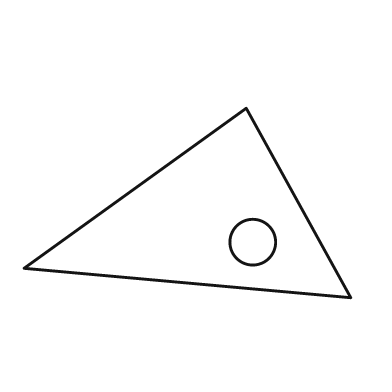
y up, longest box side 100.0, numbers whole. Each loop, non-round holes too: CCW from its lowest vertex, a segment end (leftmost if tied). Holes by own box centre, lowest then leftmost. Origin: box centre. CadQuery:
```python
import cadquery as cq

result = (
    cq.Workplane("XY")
    .moveTo(50.0, -29.0)
    .lineTo(18.0, 29.0)
    .lineTo(-50.0, -20.0)
    .close()
    .moveTo(20.0, -12.0)
    .circle(7.0)
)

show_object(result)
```